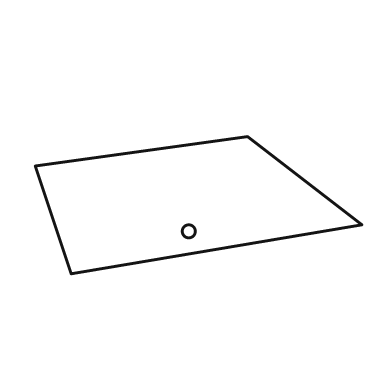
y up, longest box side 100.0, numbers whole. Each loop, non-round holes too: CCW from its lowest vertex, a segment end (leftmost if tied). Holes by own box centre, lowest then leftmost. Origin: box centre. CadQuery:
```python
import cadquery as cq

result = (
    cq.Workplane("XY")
    .moveTo(-39.0, -21.0)
    .lineTo(50.0, -6.0)
    .lineTo(15.0, 21.0)
    .lineTo(-50.0, 12.0)
    .close()
    .moveTo(-3.0, -8.0)
    .circle(2.0)
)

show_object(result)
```